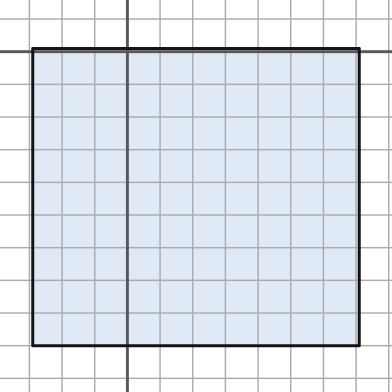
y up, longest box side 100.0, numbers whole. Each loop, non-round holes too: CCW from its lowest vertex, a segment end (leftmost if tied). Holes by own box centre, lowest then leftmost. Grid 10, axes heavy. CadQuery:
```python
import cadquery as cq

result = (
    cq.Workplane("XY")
    .moveTo(-29.0, -90.0)
    .lineTo(71.0, -90.0)
    .lineTo(71.0, 1.0)
    .lineTo(-29.0, 1.0)
    .close()
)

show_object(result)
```